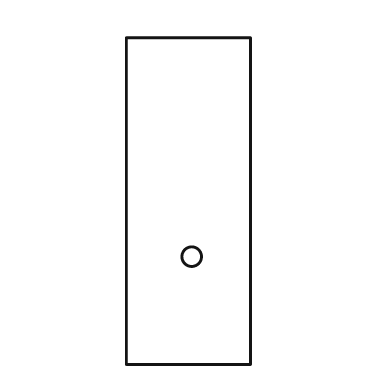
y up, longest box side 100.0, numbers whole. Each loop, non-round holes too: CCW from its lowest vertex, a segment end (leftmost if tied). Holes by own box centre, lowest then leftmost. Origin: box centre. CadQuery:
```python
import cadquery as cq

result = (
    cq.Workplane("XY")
    .moveTo(-19.0, -50.0)
    .lineTo(19.0, -50.0)
    .lineTo(19.0, 50.0)
    .lineTo(-19.0, 50.0)
    .close()
    .moveTo(1.0, -17.0)
    .circle(3.0)
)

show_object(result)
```